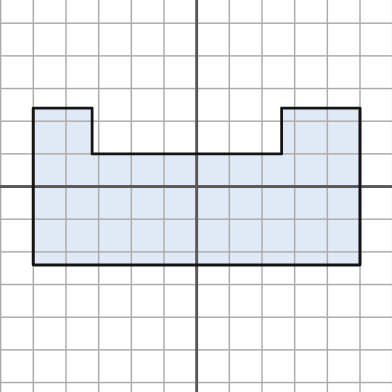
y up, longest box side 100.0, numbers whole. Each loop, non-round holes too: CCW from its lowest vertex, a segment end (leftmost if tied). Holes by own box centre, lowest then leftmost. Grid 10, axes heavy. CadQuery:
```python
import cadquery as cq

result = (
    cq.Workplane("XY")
    .moveTo(-50.0, -24.0)
    .lineTo(50.0, -24.0)
    .lineTo(50.0, 24.0)
    .lineTo(26.0, 24.0)
    .lineTo(26.0, 10.0)
    .lineTo(-32.0, 10.0)
    .lineTo(-32.0, 24.0)
    .lineTo(-50.0, 24.0)
    .close()
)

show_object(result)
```